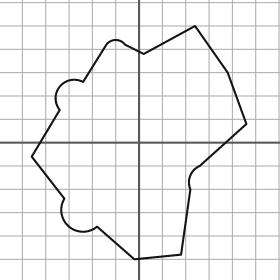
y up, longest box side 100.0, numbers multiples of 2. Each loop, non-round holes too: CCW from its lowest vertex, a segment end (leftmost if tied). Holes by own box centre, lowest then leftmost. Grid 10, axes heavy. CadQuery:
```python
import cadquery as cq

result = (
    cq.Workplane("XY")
    .moveTo(-2.0, -50.0)
    .lineTo(18.0, -48.0)
    .lineTo(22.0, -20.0)
    .threePointArc((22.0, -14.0), (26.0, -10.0))
    .lineTo(46.0, 8.0)
    .lineTo(38.0, 30.0)
    .lineTo(24.0, 50.0)
    .lineTo(2.0, 38.0)
    .lineTo(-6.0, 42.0)
    .threePointArc((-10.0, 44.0), (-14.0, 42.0))
    .lineTo(-24.0, 26.0)
    .threePointArc((-34.0, 24.0), (-34.0, 14.0))
    .lineTo(-46.0, -6.0)
    .lineTo(-32.0, -24.0)
    .threePointArc((-30.0, -36.0), (-18.0, -36.0))
    .close()
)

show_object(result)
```